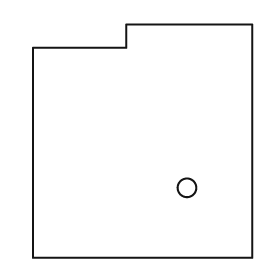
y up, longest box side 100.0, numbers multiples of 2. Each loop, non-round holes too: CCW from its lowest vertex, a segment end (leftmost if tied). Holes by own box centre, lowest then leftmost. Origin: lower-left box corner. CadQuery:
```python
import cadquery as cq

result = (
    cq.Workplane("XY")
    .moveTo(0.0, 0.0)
    .lineTo(94.0, 0.0)
    .lineTo(94.0, 100.0)
    .lineTo(40.0, 100.0)
    .lineTo(40.0, 90.0)
    .lineTo(0.0, 90.0)
    .close()
    .moveTo(66.0, 30.0)
    .circle(4.0)
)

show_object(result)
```